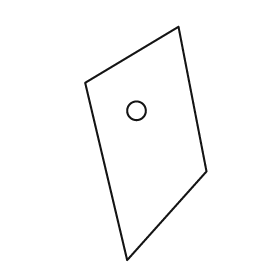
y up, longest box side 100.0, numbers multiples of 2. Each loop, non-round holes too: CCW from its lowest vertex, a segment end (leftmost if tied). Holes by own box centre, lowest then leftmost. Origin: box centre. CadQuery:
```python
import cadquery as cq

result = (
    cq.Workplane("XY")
    .moveTo(-8.0, -50.0)
    .lineTo(26.0, -12.0)
    .lineTo(14.0, 50.0)
    .lineTo(-26.0, 26.0)
    .close()
    .moveTo(-4.0, 14.0)
    .circle(4.0)
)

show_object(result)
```